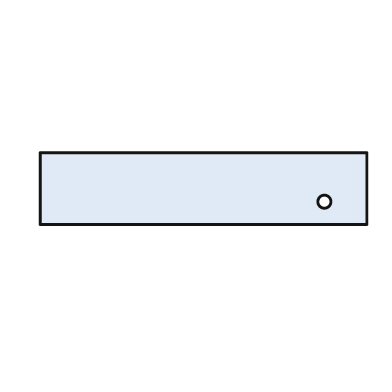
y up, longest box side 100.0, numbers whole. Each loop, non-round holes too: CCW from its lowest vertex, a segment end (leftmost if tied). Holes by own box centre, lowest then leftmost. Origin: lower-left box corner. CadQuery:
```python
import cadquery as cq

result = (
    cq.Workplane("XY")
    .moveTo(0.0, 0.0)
    .lineTo(100.0, 0.0)
    .lineTo(100.0, 22.0)
    .lineTo(0.0, 22.0)
    .close()
    .moveTo(87.0, 7.0)
    .circle(2.0)
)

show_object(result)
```